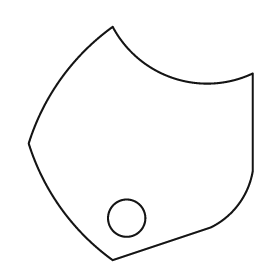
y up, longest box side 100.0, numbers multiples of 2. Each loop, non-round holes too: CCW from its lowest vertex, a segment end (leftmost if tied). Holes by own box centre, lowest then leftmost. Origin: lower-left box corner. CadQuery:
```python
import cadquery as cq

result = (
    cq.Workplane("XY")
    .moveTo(36.0, 0.0)
    .lineTo(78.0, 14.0)
    .threePointArc((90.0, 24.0), (96.0, 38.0))
    .lineTo(96.0, 80.0)
    .threePointArc((62.0, 78.0), (36.0, 100.0))
    .threePointArc((14.0, 78.0), (0.0, 50.0))
    .threePointArc((14.0, 22.0), (36.0, 0.0))
    .close()
    .moveTo(42.0, 18.0)
    .circle(8.0)
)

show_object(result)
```